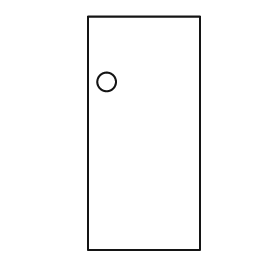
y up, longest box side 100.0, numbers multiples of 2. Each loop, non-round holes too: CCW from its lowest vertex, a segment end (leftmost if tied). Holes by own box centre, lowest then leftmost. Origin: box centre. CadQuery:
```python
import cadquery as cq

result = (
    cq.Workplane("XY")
    .moveTo(-24.0, -50.0)
    .lineTo(24.0, -50.0)
    .lineTo(24.0, 50.0)
    .lineTo(-24.0, 50.0)
    .close()
    .moveTo(-16.0, 22.0)
    .circle(4.0)
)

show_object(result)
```